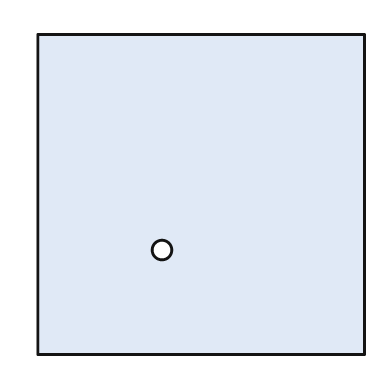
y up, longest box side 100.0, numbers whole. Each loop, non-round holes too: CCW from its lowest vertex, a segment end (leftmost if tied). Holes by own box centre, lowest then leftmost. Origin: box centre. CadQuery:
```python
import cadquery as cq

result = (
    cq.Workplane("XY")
    .moveTo(-50.0, -49.0)
    .lineTo(50.0, -49.0)
    .lineTo(50.0, 49.0)
    .lineTo(-50.0, 49.0)
    .close()
    .moveTo(-12.0, -17.0)
    .circle(3.0)
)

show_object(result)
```